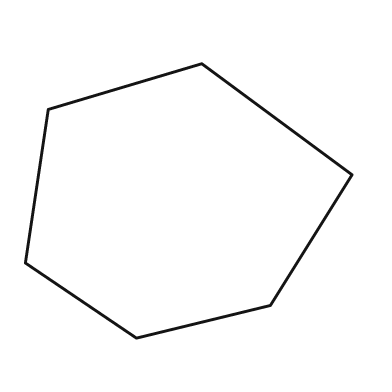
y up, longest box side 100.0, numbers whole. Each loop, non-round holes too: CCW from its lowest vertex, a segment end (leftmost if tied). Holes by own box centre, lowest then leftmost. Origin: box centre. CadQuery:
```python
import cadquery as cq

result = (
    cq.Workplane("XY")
    .moveTo(-16.0, -42.0)
    .lineTo(25.0, -32.0)
    .lineTo(50.0, 8.0)
    .lineTo(4.0, 42.0)
    .lineTo(-43.0, 28.0)
    .lineTo(-50.0, -19.0)
    .close()
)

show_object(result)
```